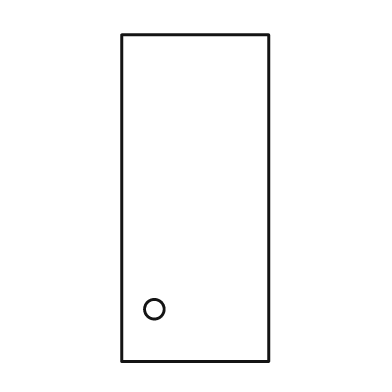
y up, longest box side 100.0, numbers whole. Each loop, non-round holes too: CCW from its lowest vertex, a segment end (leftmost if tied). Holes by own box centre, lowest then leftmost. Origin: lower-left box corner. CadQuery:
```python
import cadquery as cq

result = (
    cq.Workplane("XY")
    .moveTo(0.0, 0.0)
    .lineTo(45.0, 0.0)
    .lineTo(45.0, 100.0)
    .lineTo(0.0, 100.0)
    .close()
    .moveTo(10.0, 16.0)
    .circle(3.0)
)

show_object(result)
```